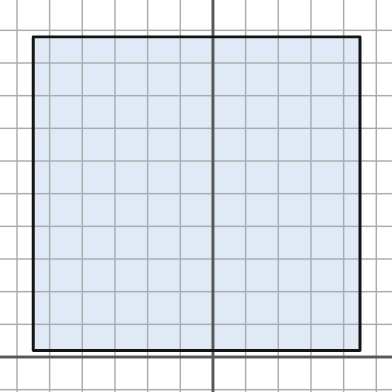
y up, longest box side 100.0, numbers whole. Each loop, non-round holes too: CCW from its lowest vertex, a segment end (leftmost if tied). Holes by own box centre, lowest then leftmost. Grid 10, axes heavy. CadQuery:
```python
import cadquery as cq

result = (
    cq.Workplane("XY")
    .moveTo(-55.0, 2.0)
    .lineTo(45.0, 2.0)
    .lineTo(45.0, 98.0)
    .lineTo(-55.0, 98.0)
    .close()
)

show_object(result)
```